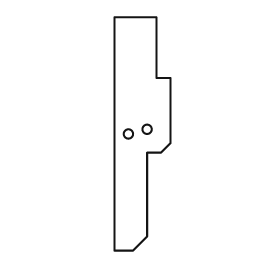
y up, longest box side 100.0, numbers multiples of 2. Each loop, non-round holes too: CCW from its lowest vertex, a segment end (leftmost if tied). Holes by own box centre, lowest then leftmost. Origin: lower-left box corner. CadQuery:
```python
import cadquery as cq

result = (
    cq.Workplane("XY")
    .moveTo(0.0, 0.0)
    .lineTo(8.0, 0.0)
    .lineTo(14.0, 6.0)
    .lineTo(14.0, 42.0)
    .lineTo(20.0, 42.0)
    .lineTo(24.0, 46.0)
    .lineTo(24.0, 74.0)
    .lineTo(18.0, 74.0)
    .lineTo(18.0, 100.0)
    .lineTo(0.0, 100.0)
    .close()
    .moveTo(6.0, 50.0)
    .circle(2.0)
    .moveTo(14.0, 52.0)
    .circle(2.0)
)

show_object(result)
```